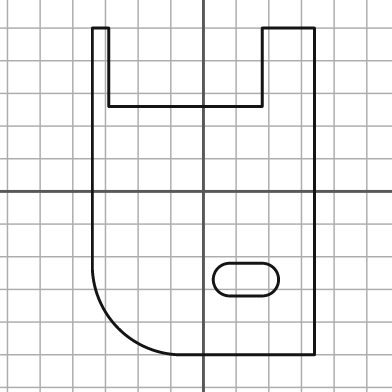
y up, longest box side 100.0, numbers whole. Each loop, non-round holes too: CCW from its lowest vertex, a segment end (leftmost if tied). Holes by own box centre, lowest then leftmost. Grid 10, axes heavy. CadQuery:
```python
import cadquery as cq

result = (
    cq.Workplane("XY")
    .moveTo(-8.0, -50.0)
    .lineTo(34.0, -50.0)
    .lineTo(34.0, 50.0)
    .lineTo(18.0, 50.0)
    .lineTo(18.0, 26.0)
    .lineTo(-29.0, 26.0)
    .lineTo(-29.0, 50.0)
    .lineTo(-34.0, 50.0)
    .lineTo(-34.0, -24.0)
    .threePointArc((-26.0, -42.0), (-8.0, -50.0))
    .close()
    .moveTo(8.0, -32.0)
    .lineTo(18.0, -32.0)
    .threePointArc((23.0, -27.0), (18.0, -22.0))
    .lineTo(8.0, -22.0)
    .threePointArc((3.0, -27.0), (8.0, -32.0))
    .close()
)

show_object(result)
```